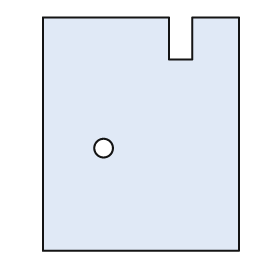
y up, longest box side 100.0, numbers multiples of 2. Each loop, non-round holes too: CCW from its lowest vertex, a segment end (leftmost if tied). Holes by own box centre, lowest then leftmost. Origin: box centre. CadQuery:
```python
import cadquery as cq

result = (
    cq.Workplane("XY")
    .moveTo(-42.0, -50.0)
    .lineTo(42.0, -50.0)
    .lineTo(42.0, 50.0)
    .lineTo(22.0, 50.0)
    .lineTo(22.0, 32.0)
    .lineTo(12.0, 32.0)
    .lineTo(12.0, 50.0)
    .lineTo(-42.0, 50.0)
    .close()
    .moveTo(-16.0, -6.0)
    .circle(4.0)
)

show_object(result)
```